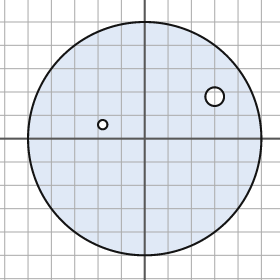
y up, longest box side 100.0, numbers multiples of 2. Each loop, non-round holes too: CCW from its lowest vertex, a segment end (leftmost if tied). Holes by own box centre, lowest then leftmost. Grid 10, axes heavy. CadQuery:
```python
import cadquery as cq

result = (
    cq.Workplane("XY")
    .moveTo(0.0, 0.0)
    .circle(50.0)
    .moveTo(-18.0, 6.0)
    .circle(2.0)
    .moveTo(30.0, 18.0)
    .circle(4.0)
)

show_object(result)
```